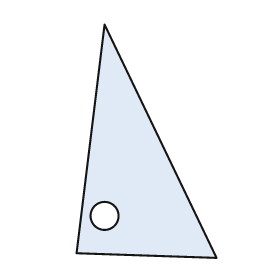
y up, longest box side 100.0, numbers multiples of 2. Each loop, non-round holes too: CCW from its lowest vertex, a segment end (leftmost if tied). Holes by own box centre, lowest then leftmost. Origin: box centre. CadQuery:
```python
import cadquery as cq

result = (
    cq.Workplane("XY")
    .moveTo(30.0, -50.0)
    .lineTo(-18.0, 50.0)
    .lineTo(-30.0, -48.0)
    .close()
    .moveTo(-18.0, -32.0)
    .circle(6.0)
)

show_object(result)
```